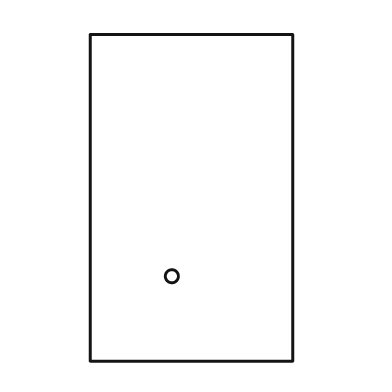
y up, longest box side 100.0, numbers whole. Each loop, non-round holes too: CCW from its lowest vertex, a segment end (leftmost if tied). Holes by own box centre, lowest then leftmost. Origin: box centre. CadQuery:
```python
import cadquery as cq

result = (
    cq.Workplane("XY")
    .moveTo(-31.0, -50.0)
    .lineTo(31.0, -50.0)
    .lineTo(31.0, 50.0)
    .lineTo(-31.0, 50.0)
    .close()
    .moveTo(-6.0, -24.0)
    .circle(2.0)
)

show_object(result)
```